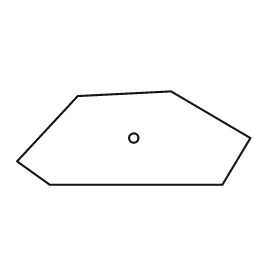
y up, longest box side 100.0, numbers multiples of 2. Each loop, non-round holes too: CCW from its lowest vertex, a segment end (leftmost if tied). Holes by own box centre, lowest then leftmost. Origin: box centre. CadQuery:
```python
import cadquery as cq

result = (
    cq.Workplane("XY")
    .moveTo(-36.0, -20.0)
    .lineTo(38.0, -20.0)
    .lineTo(50.0, 0.0)
    .lineTo(16.0, 20.0)
    .lineTo(-24.0, 18.0)
    .lineTo(-50.0, -10.0)
    .close()
    .moveTo(0.0, 0.0)
    .circle(2.0)
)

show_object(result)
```